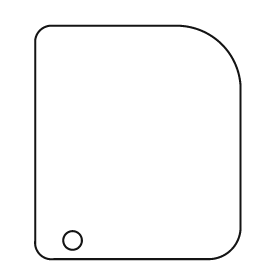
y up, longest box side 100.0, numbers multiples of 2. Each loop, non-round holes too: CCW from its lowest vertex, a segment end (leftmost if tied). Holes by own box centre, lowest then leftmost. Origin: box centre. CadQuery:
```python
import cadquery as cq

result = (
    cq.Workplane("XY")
    .moveTo(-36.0, -50.0)
    .lineTo(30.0, -50.0)
    .threePointArc((40.0, -46.0), (44.0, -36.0))
    .lineTo(44.0, 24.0)
    .threePointArc((36.0, 42.0), (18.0, 50.0))
    .lineTo(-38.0, 50.0)
    .threePointArc((-42.0, 48.0), (-44.0, 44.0))
    .lineTo(-44.0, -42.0)
    .threePointArc((-42.0, -48.0), (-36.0, -50.0))
    .close()
    .moveTo(-28.0, -42.0)
    .circle(4.0)
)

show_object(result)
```